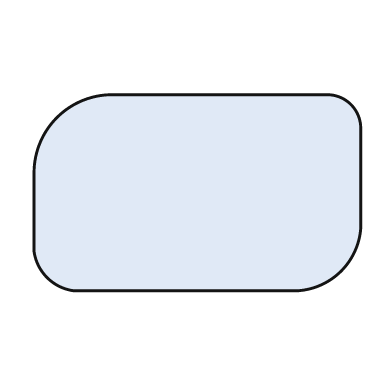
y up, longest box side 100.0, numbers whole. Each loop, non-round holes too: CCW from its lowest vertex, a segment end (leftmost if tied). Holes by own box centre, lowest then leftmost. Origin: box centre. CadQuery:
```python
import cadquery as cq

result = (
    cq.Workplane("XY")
    .moveTo(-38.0, -30.0)
    .lineTo(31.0, -30.0)
    .threePointArc((44.0, -24.0), (50.0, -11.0))
    .lineTo(50.0, 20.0)
    .threePointArc((47.0, 27.0), (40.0, 30.0))
    .lineTo(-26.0, 30.0)
    .threePointArc((-43.0, 23.0), (-50.0, 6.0))
    .lineTo(-50.0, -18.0)
    .threePointArc((-46.0, -26.0), (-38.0, -30.0))
    .close()
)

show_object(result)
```